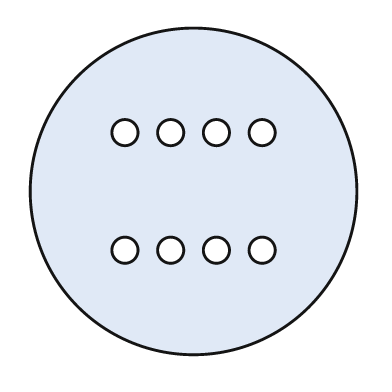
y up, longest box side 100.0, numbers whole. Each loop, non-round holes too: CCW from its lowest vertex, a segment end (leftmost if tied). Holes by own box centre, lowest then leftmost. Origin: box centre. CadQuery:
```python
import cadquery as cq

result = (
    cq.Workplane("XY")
    .moveTo(0.0, 0.0)
    .circle(50.0)
    .moveTo(-21.0, -18.0)
    .circle(4.0)
    .moveTo(-7.0, -18.0)
    .circle(4.0)
    .moveTo(7.0, -18.0)
    .circle(4.0)
    .moveTo(21.0, -18.0)
    .circle(4.0)
    .moveTo(-21.0, 18.0)
    .circle(4.0)
    .moveTo(-7.0, 18.0)
    .circle(4.0)
    .moveTo(7.0, 18.0)
    .circle(4.0)
    .moveTo(21.0, 18.0)
    .circle(4.0)
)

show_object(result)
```